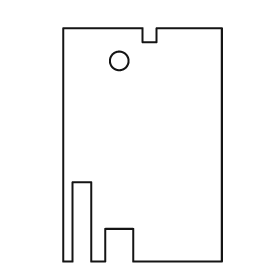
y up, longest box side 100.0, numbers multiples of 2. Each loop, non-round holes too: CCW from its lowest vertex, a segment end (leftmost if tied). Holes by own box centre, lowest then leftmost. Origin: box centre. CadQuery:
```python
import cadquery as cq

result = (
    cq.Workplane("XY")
    .moveTo(-34.0, -50.0)
    .lineTo(-30.0, -50.0)
    .lineTo(-30.0, -16.0)
    .lineTo(-22.0, -16.0)
    .lineTo(-22.0, -50.0)
    .lineTo(-16.0, -50.0)
    .lineTo(-16.0, -36.0)
    .lineTo(-4.0, -36.0)
    .lineTo(-4.0, -50.0)
    .lineTo(34.0, -50.0)
    .lineTo(34.0, 50.0)
    .lineTo(6.0, 50.0)
    .lineTo(6.0, 44.0)
    .lineTo(0.0, 44.0)
    .lineTo(0.0, 50.0)
    .lineTo(-34.0, 50.0)
    .close()
    .moveTo(-10.0, 36.0)
    .circle(4.0)
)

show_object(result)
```